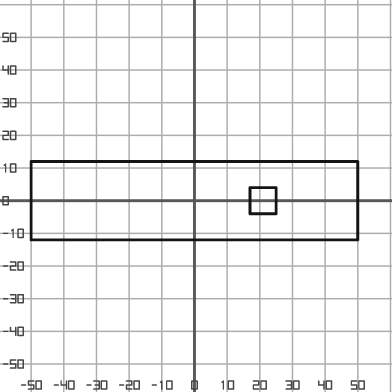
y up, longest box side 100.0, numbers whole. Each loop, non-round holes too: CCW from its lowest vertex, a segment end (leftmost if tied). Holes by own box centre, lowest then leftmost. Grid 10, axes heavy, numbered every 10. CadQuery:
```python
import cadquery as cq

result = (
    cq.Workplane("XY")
    .moveTo(-50.0, -12.0)
    .lineTo(50.0, -12.0)
    .lineTo(50.0, 12.0)
    .lineTo(-50.0, 12.0)
    .close()
    .moveTo(17.0, -4.0)
    .lineTo(25.0, -4.0)
    .lineTo(25.0, 4.0)
    .lineTo(17.0, 4.0)
    .close()
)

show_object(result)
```